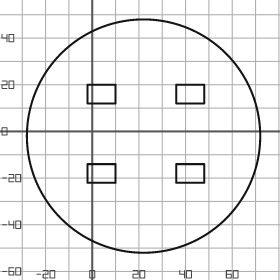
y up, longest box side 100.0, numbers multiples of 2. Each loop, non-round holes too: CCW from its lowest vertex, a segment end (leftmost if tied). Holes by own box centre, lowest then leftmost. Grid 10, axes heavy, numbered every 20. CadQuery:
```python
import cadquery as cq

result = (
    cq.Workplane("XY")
    .moveTo(22.0, -2.0)
    .circle(50.0)
    .moveTo(-2.0, -22.0)
    .lineTo(10.0, -22.0)
    .lineTo(10.0, -14.0)
    .lineTo(-2.0, -14.0)
    .close()
    .moveTo(36.0, -22.0)
    .lineTo(48.0, -22.0)
    .lineTo(48.0, -14.0)
    .lineTo(36.0, -14.0)
    .close()
    .moveTo(-2.0, 12.0)
    .lineTo(10.0, 12.0)
    .lineTo(10.0, 20.0)
    .lineTo(-2.0, 20.0)
    .close()
    .moveTo(36.0, 12.0)
    .lineTo(48.0, 12.0)
    .lineTo(48.0, 20.0)
    .lineTo(36.0, 20.0)
    .close()
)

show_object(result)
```